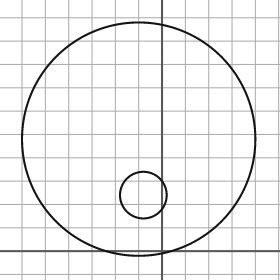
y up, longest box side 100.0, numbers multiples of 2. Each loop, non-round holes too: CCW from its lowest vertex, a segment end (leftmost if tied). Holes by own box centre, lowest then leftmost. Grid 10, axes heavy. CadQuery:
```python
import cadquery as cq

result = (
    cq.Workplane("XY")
    .moveTo(-10.0, 48.0)
    .circle(50.0)
    .moveTo(-8.0, 24.0)
    .circle(10.0)
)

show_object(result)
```